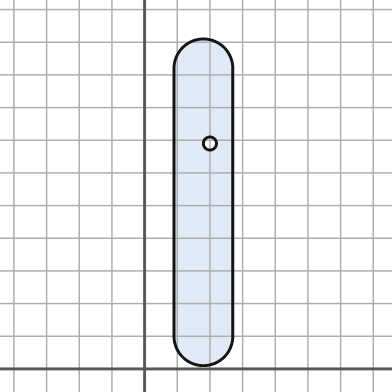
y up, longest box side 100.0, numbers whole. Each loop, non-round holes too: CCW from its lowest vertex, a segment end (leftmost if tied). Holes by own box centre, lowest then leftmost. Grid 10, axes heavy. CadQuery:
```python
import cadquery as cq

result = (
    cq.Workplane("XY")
    .moveTo(9.0, 10.0)
    .threePointArc((18.0, 1.0), (27.0, 10.0))
    .lineTo(27.0, 92.0)
    .threePointArc((18.0, 101.0), (9.0, 92.0))
    .close()
    .moveTo(20.0, 69.0)
    .circle(2.0)
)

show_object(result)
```